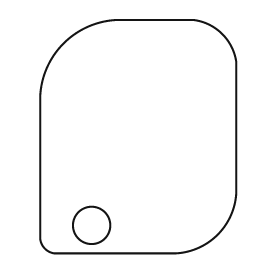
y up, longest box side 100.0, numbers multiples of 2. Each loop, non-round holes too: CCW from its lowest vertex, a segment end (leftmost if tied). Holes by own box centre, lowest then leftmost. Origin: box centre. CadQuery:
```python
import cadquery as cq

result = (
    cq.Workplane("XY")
    .moveTo(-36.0, -50.0)
    .lineTo(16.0, -50.0)
    .threePointArc((34.0, -42.0), (42.0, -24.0))
    .lineTo(42.0, 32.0)
    .threePointArc((36.0, 44.0), (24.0, 50.0))
    .lineTo(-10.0, 50.0)
    .threePointArc((-32.0, 40.0), (-42.0, 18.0))
    .lineTo(-42.0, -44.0)
    .threePointArc((-40.0, -48.0), (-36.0, -50.0))
    .close()
    .moveTo(-20.0, -38.0)
    .circle(8.0)
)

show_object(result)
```